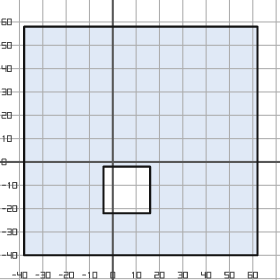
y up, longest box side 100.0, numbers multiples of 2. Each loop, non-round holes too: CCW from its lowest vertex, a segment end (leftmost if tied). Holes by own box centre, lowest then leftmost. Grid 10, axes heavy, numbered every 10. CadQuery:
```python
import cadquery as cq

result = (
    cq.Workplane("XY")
    .moveTo(-38.0, -40.0)
    .lineTo(62.0, -40.0)
    .lineTo(62.0, 58.0)
    .lineTo(-38.0, 58.0)
    .close()
    .moveTo(-4.0, -22.0)
    .lineTo(16.0, -22.0)
    .lineTo(16.0, -2.0)
    .lineTo(-4.0, -2.0)
    .close()
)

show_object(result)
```